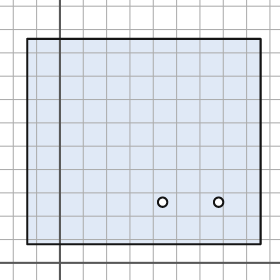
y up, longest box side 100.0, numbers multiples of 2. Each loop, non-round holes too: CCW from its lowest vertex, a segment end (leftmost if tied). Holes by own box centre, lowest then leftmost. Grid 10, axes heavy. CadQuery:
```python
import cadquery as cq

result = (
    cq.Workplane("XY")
    .moveTo(-14.0, 8.0)
    .lineTo(86.0, 8.0)
    .lineTo(86.0, 96.0)
    .lineTo(-14.0, 96.0)
    .close()
    .moveTo(44.0, 26.0)
    .circle(2.0)
    .moveTo(68.0, 26.0)
    .circle(2.0)
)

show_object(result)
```